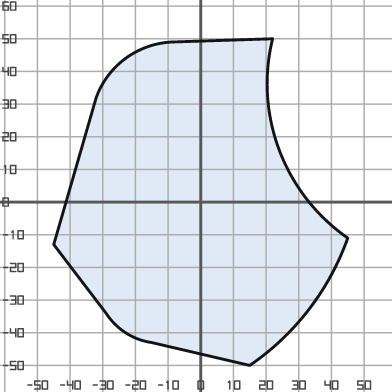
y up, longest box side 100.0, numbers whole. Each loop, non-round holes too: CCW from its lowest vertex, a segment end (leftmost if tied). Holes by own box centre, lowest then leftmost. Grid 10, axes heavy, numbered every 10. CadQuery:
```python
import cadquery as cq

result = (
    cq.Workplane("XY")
    .moveTo(15.0, -50.0)
    .threePointArc((33.0, -33.0), (45.0, -11.0))
    .threePointArc((24.0, 16.0), (22.0, 50.0))
    .lineTo(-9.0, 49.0)
    .threePointArc((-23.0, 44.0), (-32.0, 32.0))
    .lineTo(-45.0, -13.0)
    .lineTo(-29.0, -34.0)
    .threePointArc((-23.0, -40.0), (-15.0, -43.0))
    .close()
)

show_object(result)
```